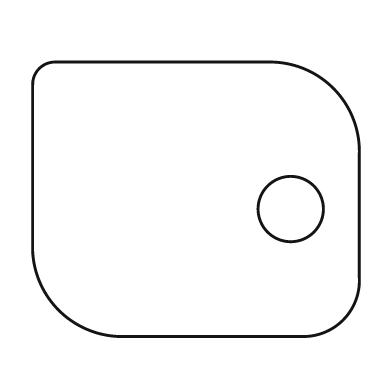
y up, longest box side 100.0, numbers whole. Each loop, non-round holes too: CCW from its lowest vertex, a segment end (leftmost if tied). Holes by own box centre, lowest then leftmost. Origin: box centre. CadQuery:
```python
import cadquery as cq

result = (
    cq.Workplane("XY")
    .moveTo(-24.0, -42.0)
    .lineTo(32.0, -42.0)
    .threePointArc((45.0, -37.0), (50.0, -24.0))
    .lineTo(50.0, 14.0)
    .threePointArc((42.0, 34.0), (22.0, 42.0))
    .lineTo(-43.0, 42.0)
    .threePointArc((-48.0, 40.0), (-50.0, 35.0))
    .lineTo(-50.0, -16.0)
    .threePointArc((-42.0, -34.0), (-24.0, -42.0))
    .close()
    .moveTo(29.0, -3.0)
    .circle(10.0)
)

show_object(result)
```